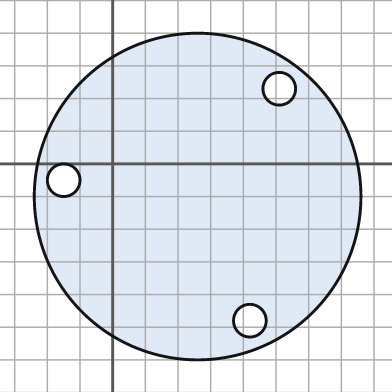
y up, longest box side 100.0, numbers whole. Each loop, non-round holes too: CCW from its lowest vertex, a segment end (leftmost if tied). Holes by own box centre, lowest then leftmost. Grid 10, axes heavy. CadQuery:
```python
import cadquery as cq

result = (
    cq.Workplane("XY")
    .moveTo(26.0, -10.0)
    .circle(50.0)
    .moveTo(42.0, -48.0)
    .circle(5.0)
    .moveTo(-15.0, -5.0)
    .circle(5.0)
    .moveTo(51.0, 23.0)
    .circle(5.0)
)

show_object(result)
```